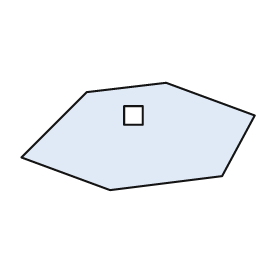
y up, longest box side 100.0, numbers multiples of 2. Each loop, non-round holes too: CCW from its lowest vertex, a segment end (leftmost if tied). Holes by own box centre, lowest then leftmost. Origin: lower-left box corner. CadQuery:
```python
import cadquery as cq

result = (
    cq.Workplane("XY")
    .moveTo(38.0, 0.0)
    .lineTo(86.0, 6.0)
    .lineTo(100.0, 32.0)
    .lineTo(62.0, 46.0)
    .lineTo(28.0, 42.0)
    .lineTo(0.0, 14.0)
    .close()
    .moveTo(44.0, 28.0)
    .lineTo(52.0, 28.0)
    .lineTo(52.0, 36.0)
    .lineTo(44.0, 36.0)
    .close()
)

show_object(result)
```